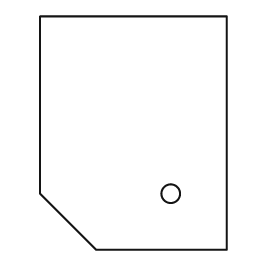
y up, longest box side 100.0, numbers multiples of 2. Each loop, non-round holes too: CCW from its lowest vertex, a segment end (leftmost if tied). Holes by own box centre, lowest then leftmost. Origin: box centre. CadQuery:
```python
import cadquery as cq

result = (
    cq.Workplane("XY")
    .moveTo(-16.0, -50.0)
    .lineTo(40.0, -50.0)
    .lineTo(40.0, 50.0)
    .lineTo(-40.0, 50.0)
    .lineTo(-40.0, -26.0)
    .close()
    .moveTo(16.0, -26.0)
    .circle(4.0)
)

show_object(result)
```